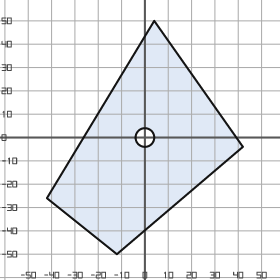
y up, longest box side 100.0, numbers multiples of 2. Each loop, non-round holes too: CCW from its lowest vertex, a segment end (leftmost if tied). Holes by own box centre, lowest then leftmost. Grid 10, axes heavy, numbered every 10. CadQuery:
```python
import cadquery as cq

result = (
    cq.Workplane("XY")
    .moveTo(-12.0, -50.0)
    .lineTo(42.0, -4.0)
    .lineTo(4.0, 50.0)
    .lineTo(-42.0, -26.0)
    .close()
    .moveTo(0.0, 0.0)
    .circle(4.0)
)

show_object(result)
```